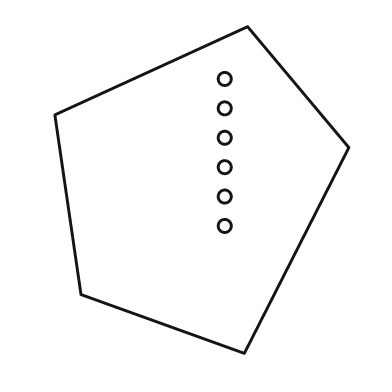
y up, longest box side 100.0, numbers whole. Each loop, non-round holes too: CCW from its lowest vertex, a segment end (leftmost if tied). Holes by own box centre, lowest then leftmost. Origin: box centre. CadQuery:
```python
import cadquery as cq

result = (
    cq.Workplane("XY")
    .moveTo(13.0, -50.0)
    .lineTo(45.0, 13.0)
    .lineTo(14.0, 50.0)
    .lineTo(-45.0, 23.0)
    .lineTo(-37.0, -32.0)
    .close()
    .moveTo(7.0, -11.0)
    .circle(2.0)
    .moveTo(7.0, -2.0)
    .circle(2.0)
    .moveTo(7.0, 7.0)
    .circle(2.0)
    .moveTo(7.0, 16.0)
    .circle(2.0)
    .moveTo(7.0, 25.0)
    .circle(2.0)
    .moveTo(7.0, 34.0)
    .circle(2.0)
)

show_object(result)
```